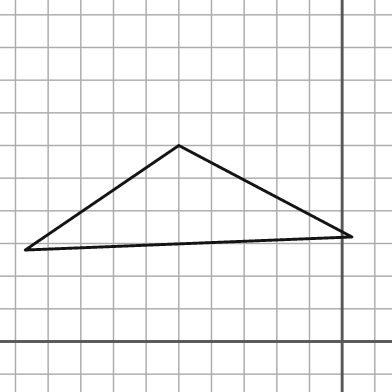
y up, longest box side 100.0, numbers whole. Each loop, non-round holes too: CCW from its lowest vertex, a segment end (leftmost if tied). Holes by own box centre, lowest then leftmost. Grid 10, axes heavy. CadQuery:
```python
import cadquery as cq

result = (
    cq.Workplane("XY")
    .moveTo(-97.0, 28.0)
    .lineTo(3.0, 32.0)
    .lineTo(-50.0, 60.0)
    .close()
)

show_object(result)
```